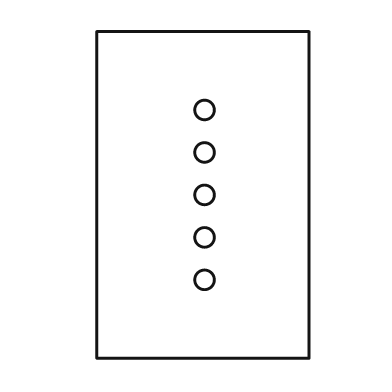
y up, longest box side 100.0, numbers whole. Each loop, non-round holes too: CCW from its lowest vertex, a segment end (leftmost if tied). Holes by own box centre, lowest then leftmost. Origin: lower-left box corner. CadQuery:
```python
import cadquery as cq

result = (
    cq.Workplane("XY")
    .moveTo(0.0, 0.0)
    .lineTo(65.0, 0.0)
    .lineTo(65.0, 100.0)
    .lineTo(0.0, 100.0)
    .close()
    .moveTo(33.0, 24.0)
    .circle(3.0)
    .moveTo(33.0, 37.0)
    .circle(3.0)
    .moveTo(33.0, 50.0)
    .circle(3.0)
    .moveTo(33.0, 63.0)
    .circle(3.0)
    .moveTo(33.0, 76.0)
    .circle(3.0)
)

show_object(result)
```